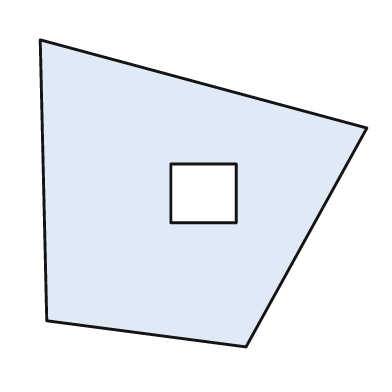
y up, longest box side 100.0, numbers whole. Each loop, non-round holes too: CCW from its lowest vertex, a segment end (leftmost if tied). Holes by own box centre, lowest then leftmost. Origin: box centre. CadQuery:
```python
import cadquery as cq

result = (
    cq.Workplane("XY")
    .moveTo(13.0, -47.0)
    .lineTo(50.0, 20.0)
    .lineTo(-50.0, 47.0)
    .lineTo(-48.0, -39.0)
    .close()
    .moveTo(-10.0, -9.0)
    .lineTo(10.0, -9.0)
    .lineTo(10.0, 9.0)
    .lineTo(-10.0, 9.0)
    .close()
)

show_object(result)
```